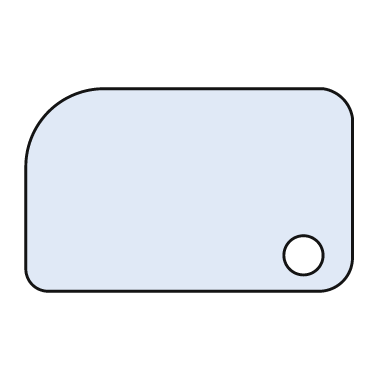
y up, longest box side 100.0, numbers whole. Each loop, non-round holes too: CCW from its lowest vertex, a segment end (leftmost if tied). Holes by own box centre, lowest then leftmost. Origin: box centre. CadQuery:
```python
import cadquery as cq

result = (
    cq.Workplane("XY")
    .moveTo(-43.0, -31.0)
    .lineTo(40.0, -31.0)
    .threePointArc((47.0, -28.0), (50.0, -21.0))
    .lineTo(50.0, 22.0)
    .threePointArc((47.0, 28.0), (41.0, 31.0))
    .lineTo(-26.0, 31.0)
    .threePointArc((-43.0, 24.0), (-50.0, 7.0))
    .lineTo(-50.0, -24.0)
    .threePointArc((-48.0, -29.0), (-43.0, -31.0))
    .close()
    .moveTo(35.0, -20.0)
    .circle(6.0)
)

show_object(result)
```